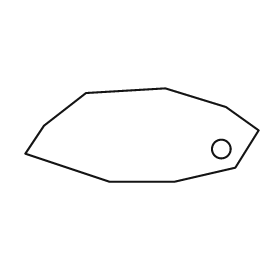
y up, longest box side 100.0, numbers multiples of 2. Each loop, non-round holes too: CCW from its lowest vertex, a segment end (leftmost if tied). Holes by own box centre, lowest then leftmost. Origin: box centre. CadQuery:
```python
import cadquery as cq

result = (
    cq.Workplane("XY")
    .moveTo(-14.0, -20.0)
    .lineTo(14.0, -20.0)
    .lineTo(40.0, -14.0)
    .lineTo(50.0, 2.0)
    .lineTo(36.0, 12.0)
    .lineTo(10.0, 20.0)
    .lineTo(-24.0, 18.0)
    .lineTo(-42.0, 4.0)
    .lineTo(-50.0, -8.0)
    .close()
    .moveTo(34.0, -6.0)
    .circle(4.0)
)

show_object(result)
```